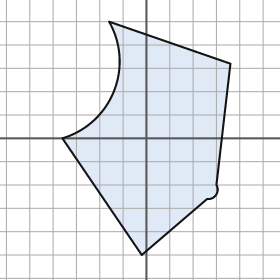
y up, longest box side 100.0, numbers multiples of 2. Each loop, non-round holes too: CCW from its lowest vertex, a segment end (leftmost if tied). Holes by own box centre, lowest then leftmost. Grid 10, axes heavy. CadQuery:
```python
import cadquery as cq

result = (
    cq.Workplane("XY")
    .moveTo(-2.0, -50.0)
    .lineTo(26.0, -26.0)
    .threePointArc((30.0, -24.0), (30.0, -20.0))
    .lineTo(36.0, 32.0)
    .lineTo(-16.0, 50.0)
    .threePointArc((-14.0, 20.0), (-36.0, 0.0))
    .close()
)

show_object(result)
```